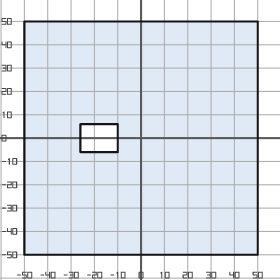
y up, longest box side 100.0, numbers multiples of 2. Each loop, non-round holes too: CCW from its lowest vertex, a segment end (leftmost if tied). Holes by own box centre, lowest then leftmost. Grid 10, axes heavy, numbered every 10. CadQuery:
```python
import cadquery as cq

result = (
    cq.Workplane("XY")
    .moveTo(-50.0, -50.0)
    .lineTo(50.0, -50.0)
    .lineTo(50.0, 50.0)
    .lineTo(-50.0, 50.0)
    .close()
    .moveTo(-26.0, -6.0)
    .lineTo(-10.0, -6.0)
    .lineTo(-10.0, 6.0)
    .lineTo(-26.0, 6.0)
    .close()
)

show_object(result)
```